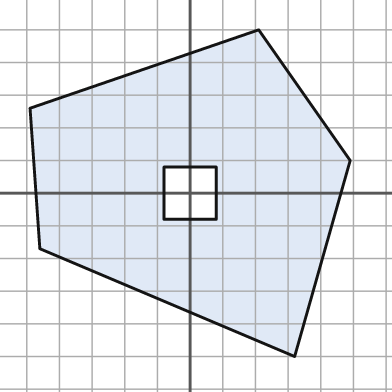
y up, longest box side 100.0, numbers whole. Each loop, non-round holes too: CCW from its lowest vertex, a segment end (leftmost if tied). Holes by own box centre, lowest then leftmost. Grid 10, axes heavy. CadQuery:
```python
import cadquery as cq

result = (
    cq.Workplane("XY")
    .moveTo(32.0, -50.0)
    .lineTo(49.0, 10.0)
    .lineTo(21.0, 50.0)
    .lineTo(-49.0, 26.0)
    .lineTo(-46.0, -17.0)
    .close()
    .moveTo(-8.0, -8.0)
    .lineTo(8.0, -8.0)
    .lineTo(8.0, 8.0)
    .lineTo(-8.0, 8.0)
    .close()
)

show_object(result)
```